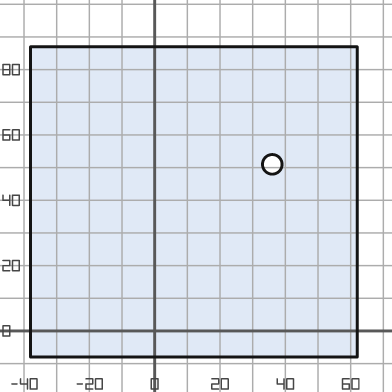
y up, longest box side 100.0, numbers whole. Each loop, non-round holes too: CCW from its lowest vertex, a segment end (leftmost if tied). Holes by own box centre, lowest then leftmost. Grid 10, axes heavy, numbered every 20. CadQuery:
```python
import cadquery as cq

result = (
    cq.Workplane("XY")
    .moveTo(-38.0, -8.0)
    .lineTo(62.0, -8.0)
    .lineTo(62.0, 87.0)
    .lineTo(-38.0, 87.0)
    .close()
    .moveTo(36.0, 51.0)
    .circle(3.0)
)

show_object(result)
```